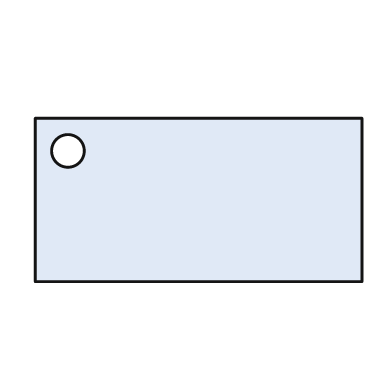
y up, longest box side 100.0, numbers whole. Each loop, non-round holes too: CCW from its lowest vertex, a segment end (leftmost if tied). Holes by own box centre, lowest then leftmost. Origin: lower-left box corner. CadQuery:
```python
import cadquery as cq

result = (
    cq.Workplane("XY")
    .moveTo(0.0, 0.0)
    .lineTo(100.0, 0.0)
    .lineTo(100.0, 50.0)
    .lineTo(0.0, 50.0)
    .close()
    .moveTo(10.0, 40.0)
    .circle(5.0)
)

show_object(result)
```